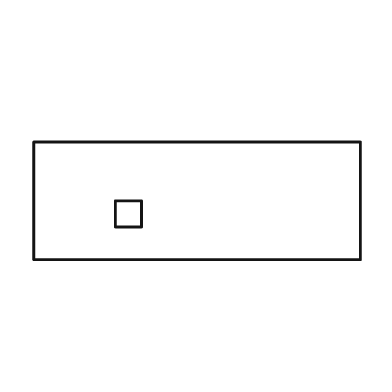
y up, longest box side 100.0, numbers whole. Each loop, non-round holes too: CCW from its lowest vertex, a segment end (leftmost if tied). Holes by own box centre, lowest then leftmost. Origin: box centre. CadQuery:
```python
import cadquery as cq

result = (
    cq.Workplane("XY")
    .moveTo(-50.0, -18.0)
    .lineTo(50.0, -18.0)
    .lineTo(50.0, 18.0)
    .lineTo(-50.0, 18.0)
    .close()
    .moveTo(-25.0, -8.0)
    .lineTo(-17.0, -8.0)
    .lineTo(-17.0, 0.0)
    .lineTo(-25.0, 0.0)
    .close()
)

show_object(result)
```